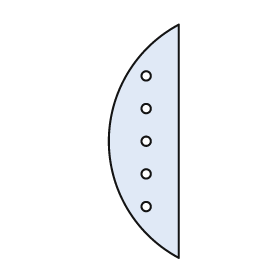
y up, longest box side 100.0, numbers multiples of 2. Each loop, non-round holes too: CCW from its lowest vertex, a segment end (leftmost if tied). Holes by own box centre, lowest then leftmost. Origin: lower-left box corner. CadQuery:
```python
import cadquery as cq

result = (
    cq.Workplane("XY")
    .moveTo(30.0, 0.0)
    .lineTo(30.0, 100.0)
    .threePointArc((0.0, 50.0), (30.0, 0.0))
    .close()
    .moveTo(16.0, 22.0)
    .circle(2.0)
    .moveTo(16.0, 36.0)
    .circle(2.0)
    .moveTo(16.0, 50.0)
    .circle(2.0)
    .moveTo(16.0, 64.0)
    .circle(2.0)
    .moveTo(16.0, 78.0)
    .circle(2.0)
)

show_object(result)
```